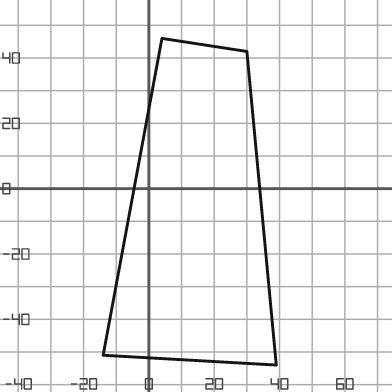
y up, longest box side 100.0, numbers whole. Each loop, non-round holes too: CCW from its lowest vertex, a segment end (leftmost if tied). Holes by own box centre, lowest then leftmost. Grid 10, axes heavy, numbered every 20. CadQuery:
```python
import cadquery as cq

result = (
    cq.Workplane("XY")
    .moveTo(39.0, -54.0)
    .lineTo(30.0, 42.0)
    .lineTo(4.0, 46.0)
    .lineTo(-14.0, -51.0)
    .close()
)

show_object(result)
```